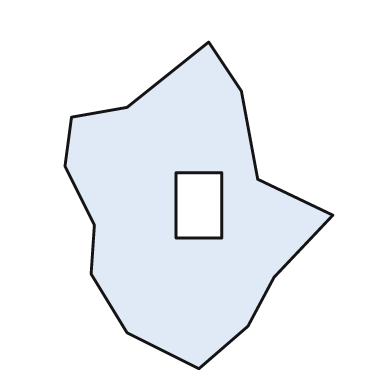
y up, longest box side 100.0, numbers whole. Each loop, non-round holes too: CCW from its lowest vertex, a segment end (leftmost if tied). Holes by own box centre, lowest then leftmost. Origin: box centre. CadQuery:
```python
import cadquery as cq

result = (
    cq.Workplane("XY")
    .moveTo(0.0, -50.0)
    .lineTo(15.0, -37.0)
    .lineTo(23.0, -22.0)
    .lineTo(41.0, -3.0)
    .lineTo(18.0, 8.0)
    .lineTo(13.0, 35.0)
    .lineTo(3.0, 50.0)
    .lineTo(-22.0, 30.0)
    .lineTo(-39.0, 27.0)
    .lineTo(-41.0, 12.0)
    .lineTo(-32.0, -6.0)
    .lineTo(-33.0, -21.0)
    .lineTo(-22.0, -39.0)
    .close()
    .moveTo(-7.0, -10.0)
    .lineTo(7.0, -10.0)
    .lineTo(7.0, 10.0)
    .lineTo(-7.0, 10.0)
    .close()
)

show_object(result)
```